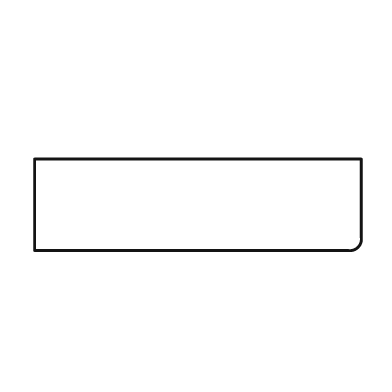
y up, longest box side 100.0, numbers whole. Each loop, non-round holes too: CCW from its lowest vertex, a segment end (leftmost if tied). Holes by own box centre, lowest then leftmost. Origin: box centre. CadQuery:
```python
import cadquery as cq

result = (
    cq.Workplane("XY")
    .moveTo(-50.0, -14.0)
    .lineTo(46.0, -14.0)
    .threePointArc((49.0, -13.0), (50.0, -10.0))
    .lineTo(50.0, 14.0)
    .lineTo(-50.0, 14.0)
    .close()
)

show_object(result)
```